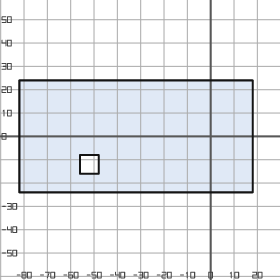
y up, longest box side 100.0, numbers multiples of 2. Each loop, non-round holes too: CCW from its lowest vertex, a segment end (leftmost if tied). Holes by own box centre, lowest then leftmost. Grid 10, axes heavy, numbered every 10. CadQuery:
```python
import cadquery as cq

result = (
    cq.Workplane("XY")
    .moveTo(-82.0, -24.0)
    .lineTo(18.0, -24.0)
    .lineTo(18.0, 24.0)
    .lineTo(-82.0, 24.0)
    .close()
    .moveTo(-56.0, -16.0)
    .lineTo(-48.0, -16.0)
    .lineTo(-48.0, -8.0)
    .lineTo(-56.0, -8.0)
    .close()
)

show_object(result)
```